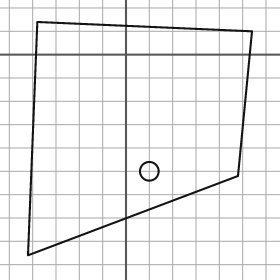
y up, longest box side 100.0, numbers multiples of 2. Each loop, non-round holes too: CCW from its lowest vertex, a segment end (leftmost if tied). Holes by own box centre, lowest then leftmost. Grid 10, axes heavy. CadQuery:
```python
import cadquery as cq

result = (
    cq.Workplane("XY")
    .moveTo(-42.0, -86.0)
    .lineTo(48.0, -52.0)
    .lineTo(54.0, 10.0)
    .lineTo(-38.0, 14.0)
    .close()
    .moveTo(10.0, -50.0)
    .circle(4.0)
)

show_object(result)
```